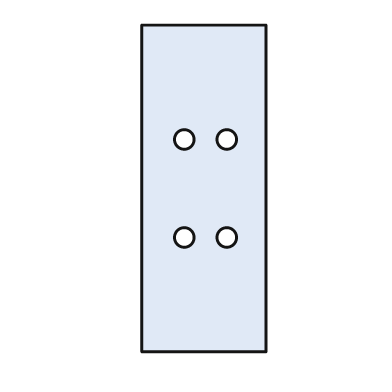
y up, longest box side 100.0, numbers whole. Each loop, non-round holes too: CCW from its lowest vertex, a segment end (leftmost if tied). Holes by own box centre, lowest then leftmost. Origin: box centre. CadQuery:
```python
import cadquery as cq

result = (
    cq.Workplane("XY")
    .moveTo(-19.0, -50.0)
    .lineTo(19.0, -50.0)
    .lineTo(19.0, 50.0)
    .lineTo(-19.0, 50.0)
    .close()
    .moveTo(-6.0, -15.0)
    .circle(3.0)
    .moveTo(7.0, -15.0)
    .circle(3.0)
    .moveTo(-6.0, 15.0)
    .circle(3.0)
    .moveTo(7.0, 15.0)
    .circle(3.0)
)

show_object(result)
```